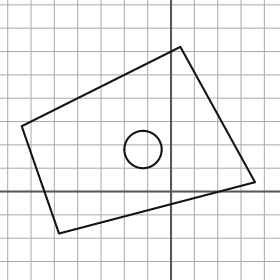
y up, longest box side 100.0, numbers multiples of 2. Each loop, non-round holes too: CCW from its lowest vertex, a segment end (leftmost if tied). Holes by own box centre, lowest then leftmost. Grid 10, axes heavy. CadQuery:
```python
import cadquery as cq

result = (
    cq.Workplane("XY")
    .moveTo(-48.0, -18.0)
    .lineTo(36.0, 4.0)
    .lineTo(4.0, 62.0)
    .lineTo(-64.0, 28.0)
    .close()
    .moveTo(-12.0, 18.0)
    .circle(8.0)
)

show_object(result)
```